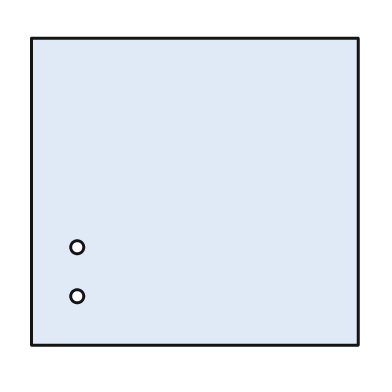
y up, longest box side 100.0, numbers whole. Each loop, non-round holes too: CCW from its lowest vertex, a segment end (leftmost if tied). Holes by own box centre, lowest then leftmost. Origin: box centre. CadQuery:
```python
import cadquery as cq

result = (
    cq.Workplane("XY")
    .moveTo(-50.0, -47.0)
    .lineTo(50.0, -47.0)
    .lineTo(50.0, 47.0)
    .lineTo(-50.0, 47.0)
    .close()
    .moveTo(-36.0, -32.0)
    .circle(2.0)
    .moveTo(-36.0, -17.0)
    .circle(2.0)
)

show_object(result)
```